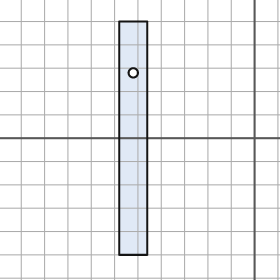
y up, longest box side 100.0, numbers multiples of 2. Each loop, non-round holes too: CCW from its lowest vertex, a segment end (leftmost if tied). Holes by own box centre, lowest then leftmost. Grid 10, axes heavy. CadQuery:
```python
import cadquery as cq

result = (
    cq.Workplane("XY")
    .moveTo(-58.0, -50.0)
    .lineTo(-46.0, -50.0)
    .lineTo(-46.0, 50.0)
    .lineTo(-58.0, 50.0)
    .close()
    .moveTo(-52.0, 28.0)
    .circle(2.0)
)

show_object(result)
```